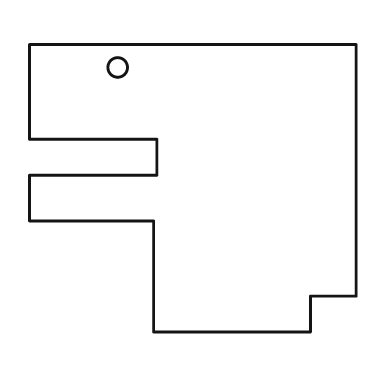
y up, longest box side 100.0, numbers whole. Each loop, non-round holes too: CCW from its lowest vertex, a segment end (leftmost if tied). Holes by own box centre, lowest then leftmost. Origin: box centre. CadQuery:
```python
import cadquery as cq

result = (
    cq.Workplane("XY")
    .moveTo(-12.0, -44.0)
    .lineTo(36.0, -44.0)
    .lineTo(36.0, -33.0)
    .lineTo(50.0, -33.0)
    .lineTo(50.0, 44.0)
    .lineTo(-50.0, 44.0)
    .lineTo(-50.0, 15.0)
    .lineTo(-11.0, 15.0)
    .lineTo(-11.0, 4.0)
    .lineTo(-50.0, 4.0)
    .lineTo(-50.0, -10.0)
    .lineTo(-12.0, -10.0)
    .close()
    .moveTo(-23.0, 37.0)
    .circle(3.0)
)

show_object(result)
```